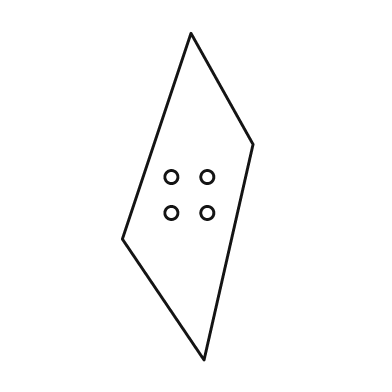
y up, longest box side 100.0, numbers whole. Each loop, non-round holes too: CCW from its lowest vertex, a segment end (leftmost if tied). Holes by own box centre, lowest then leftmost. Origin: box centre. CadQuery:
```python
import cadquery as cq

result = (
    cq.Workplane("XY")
    .moveTo(5.0, -50.0)
    .lineTo(20.0, 16.0)
    .lineTo(1.0, 50.0)
    .lineTo(-20.0, -13.0)
    .close()
    .moveTo(-5.0, -5.0)
    .circle(2.0)
    .moveTo(6.0, -5.0)
    .circle(2.0)
    .moveTo(-5.0, 6.0)
    .circle(2.0)
    .moveTo(6.0, 6.0)
    .circle(2.0)
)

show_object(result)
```